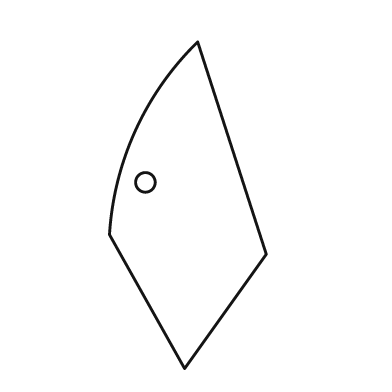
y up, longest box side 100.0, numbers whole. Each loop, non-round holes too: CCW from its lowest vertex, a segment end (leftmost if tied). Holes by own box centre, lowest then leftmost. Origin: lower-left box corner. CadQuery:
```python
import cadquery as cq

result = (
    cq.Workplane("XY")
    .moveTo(23.0, 0.0)
    .lineTo(48.0, 35.0)
    .lineTo(27.0, 100.0)
    .threePointArc((8.0, 73.0), (0.0, 41.0))
    .close()
    .moveTo(11.0, 57.0)
    .circle(3.0)
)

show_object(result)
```